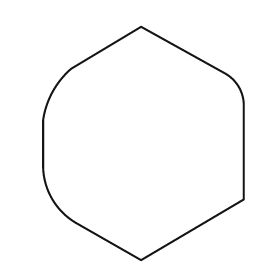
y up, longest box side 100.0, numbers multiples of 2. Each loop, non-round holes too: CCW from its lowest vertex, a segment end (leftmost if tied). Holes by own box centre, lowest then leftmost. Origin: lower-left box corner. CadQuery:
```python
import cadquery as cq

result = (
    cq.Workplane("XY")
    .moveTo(42.0, 0.0)
    .lineTo(86.0, 26.0)
    .lineTo(86.0, 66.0)
    .threePointArc((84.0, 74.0), (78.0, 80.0))
    .lineTo(42.0, 100.0)
    .lineTo(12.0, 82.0)
    .threePointArc((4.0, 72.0), (0.0, 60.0))
    .lineTo(0.0, 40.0)
    .threePointArc((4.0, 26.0), (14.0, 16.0))
    .close()
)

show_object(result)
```